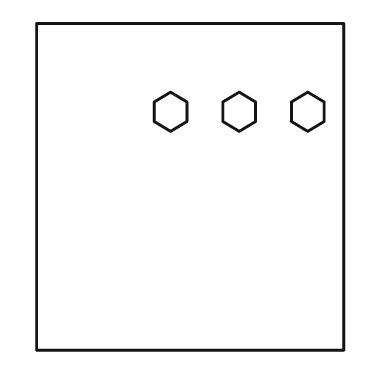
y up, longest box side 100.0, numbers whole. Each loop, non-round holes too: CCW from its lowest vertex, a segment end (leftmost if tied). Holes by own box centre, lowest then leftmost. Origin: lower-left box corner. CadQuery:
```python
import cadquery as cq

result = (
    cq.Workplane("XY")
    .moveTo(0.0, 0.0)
    .lineTo(94.0, 0.0)
    .lineTo(94.0, 100.0)
    .lineTo(0.0, 100.0)
    .close()
    .moveTo(41.0, 67.0)
    .lineTo(46.0, 70.0)
    .lineTo(46.0, 76.0)
    .lineTo(41.0, 79.0)
    .lineTo(36.0, 76.0)
    .lineTo(36.0, 70.0)
    .close()
    .moveTo(62.0, 67.0)
    .lineTo(67.0, 70.0)
    .lineTo(67.0, 76.0)
    .lineTo(62.0, 79.0)
    .lineTo(57.0, 76.0)
    .lineTo(57.0, 70.0)
    .close()
    .moveTo(83.0, 67.0)
    .lineTo(88.0, 70.0)
    .lineTo(88.0, 76.0)
    .lineTo(83.0, 79.0)
    .lineTo(78.0, 76.0)
    .lineTo(78.0, 70.0)
    .close()
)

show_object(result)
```